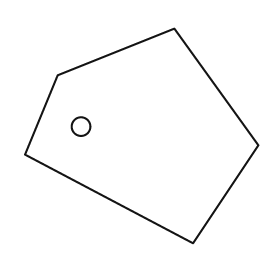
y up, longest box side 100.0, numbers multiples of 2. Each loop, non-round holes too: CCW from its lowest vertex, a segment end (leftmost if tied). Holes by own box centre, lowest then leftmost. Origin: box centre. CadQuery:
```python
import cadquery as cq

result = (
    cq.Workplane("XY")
    .moveTo(22.0, -46.0)
    .lineTo(50.0, -4.0)
    .lineTo(14.0, 46.0)
    .lineTo(-36.0, 26.0)
    .lineTo(-50.0, -8.0)
    .close()
    .moveTo(-26.0, 4.0)
    .circle(4.0)
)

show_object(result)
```